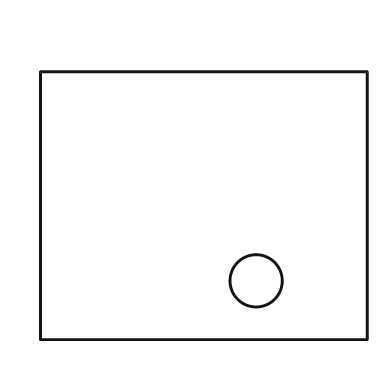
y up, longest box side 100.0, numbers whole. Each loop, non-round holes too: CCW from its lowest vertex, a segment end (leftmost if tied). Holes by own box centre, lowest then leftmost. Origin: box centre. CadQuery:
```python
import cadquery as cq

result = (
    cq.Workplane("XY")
    .moveTo(-50.0, -41.0)
    .lineTo(50.0, -41.0)
    .lineTo(50.0, 41.0)
    .lineTo(-50.0, 41.0)
    .close()
    .moveTo(16.0, -23.0)
    .circle(8.0)
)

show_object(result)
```